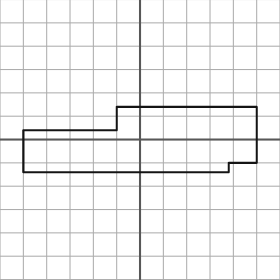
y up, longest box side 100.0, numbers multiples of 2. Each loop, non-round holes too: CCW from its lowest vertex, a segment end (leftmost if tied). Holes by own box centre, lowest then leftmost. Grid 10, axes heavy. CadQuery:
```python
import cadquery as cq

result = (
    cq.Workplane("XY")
    .moveTo(-50.0, -14.0)
    .lineTo(38.0, -14.0)
    .lineTo(38.0, -10.0)
    .lineTo(50.0, -10.0)
    .lineTo(50.0, 14.0)
    .lineTo(-10.0, 14.0)
    .lineTo(-10.0, 4.0)
    .lineTo(-50.0, 4.0)
    .close()
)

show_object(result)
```